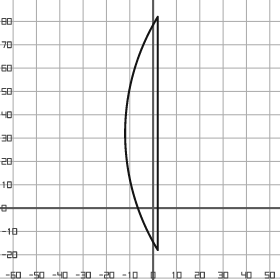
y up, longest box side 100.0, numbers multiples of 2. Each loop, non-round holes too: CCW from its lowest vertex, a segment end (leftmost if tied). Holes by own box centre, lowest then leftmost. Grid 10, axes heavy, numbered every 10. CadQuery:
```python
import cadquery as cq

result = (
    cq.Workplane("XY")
    .moveTo(2.0, -18.0)
    .lineTo(2.0, 82.0)
    .threePointArc((-12.0, 32.0), (2.0, -18.0))
    .close()
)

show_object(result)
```